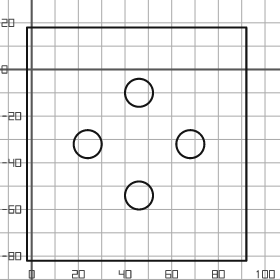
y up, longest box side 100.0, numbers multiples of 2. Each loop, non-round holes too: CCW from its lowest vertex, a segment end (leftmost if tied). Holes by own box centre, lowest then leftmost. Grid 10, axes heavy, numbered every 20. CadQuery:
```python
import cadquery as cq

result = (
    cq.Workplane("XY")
    .moveTo(-2.0, -82.0)
    .lineTo(92.0, -82.0)
    .lineTo(92.0, 18.0)
    .lineTo(-2.0, 18.0)
    .close()
    .moveTo(46.0, -54.0)
    .circle(6.0)
    .moveTo(24.0, -32.0)
    .circle(6.0)
    .moveTo(68.0, -32.0)
    .circle(6.0)
    .moveTo(46.0, -10.0)
    .circle(6.0)
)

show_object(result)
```